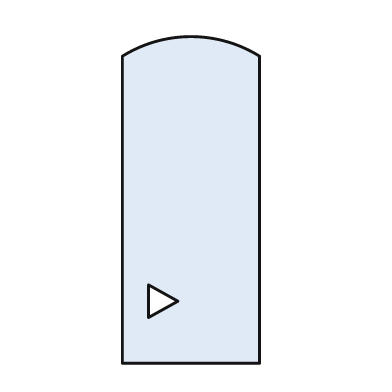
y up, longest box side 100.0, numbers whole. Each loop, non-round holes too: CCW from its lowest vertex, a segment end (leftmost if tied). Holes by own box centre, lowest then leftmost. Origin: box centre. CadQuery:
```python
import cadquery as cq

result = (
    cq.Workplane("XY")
    .moveTo(-21.0, -50.0)
    .lineTo(21.0, -50.0)
    .lineTo(21.0, 44.0)
    .threePointArc((0.0, 50.0), (-21.0, 44.0))
    .close()
    .moveTo(-13.0, -36.0)
    .lineTo(-4.0, -31.0)
    .lineTo(-13.0, -26.0)
    .close()
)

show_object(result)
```